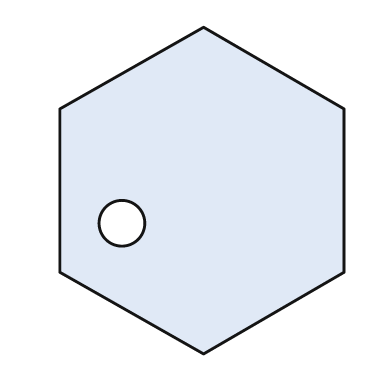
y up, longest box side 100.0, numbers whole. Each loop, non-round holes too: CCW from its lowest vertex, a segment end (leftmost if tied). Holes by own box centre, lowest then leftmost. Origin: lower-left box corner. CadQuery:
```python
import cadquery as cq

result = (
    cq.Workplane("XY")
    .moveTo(44.0, 0.0)
    .lineTo(87.0, 25.0)
    .lineTo(87.0, 75.0)
    .lineTo(44.0, 100.0)
    .lineTo(0.0, 75.0)
    .lineTo(0.0, 25.0)
    .close()
    .moveTo(19.0, 40.0)
    .circle(7.0)
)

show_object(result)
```